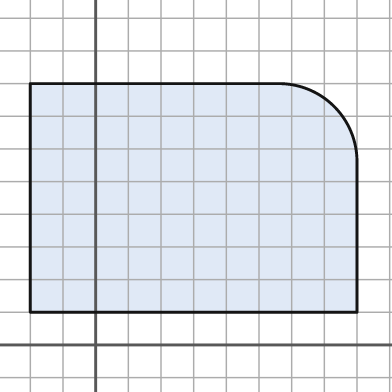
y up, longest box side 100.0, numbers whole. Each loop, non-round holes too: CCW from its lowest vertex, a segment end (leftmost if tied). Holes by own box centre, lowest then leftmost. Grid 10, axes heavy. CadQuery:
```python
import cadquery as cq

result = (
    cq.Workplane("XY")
    .moveTo(-20.0, 10.0)
    .lineTo(80.0, 10.0)
    .lineTo(80.0, 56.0)
    .threePointArc((73.0, 73.0), (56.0, 80.0))
    .lineTo(-20.0, 80.0)
    .close()
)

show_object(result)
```